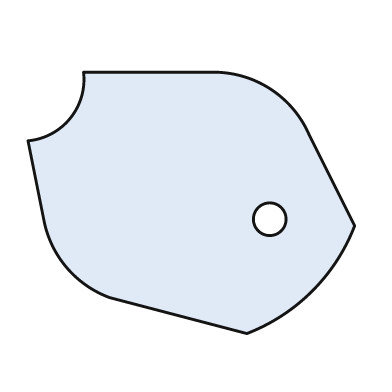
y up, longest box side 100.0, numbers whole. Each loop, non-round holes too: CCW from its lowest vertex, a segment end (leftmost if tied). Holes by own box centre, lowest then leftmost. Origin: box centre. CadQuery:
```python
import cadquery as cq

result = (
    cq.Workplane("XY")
    .moveTo(17.0, -40.0)
    .threePointArc((37.0, -27.0), (50.0, -7.0))
    .lineTo(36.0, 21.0)
    .threePointArc((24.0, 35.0), (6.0, 40.0))
    .lineTo(-33.0, 40.0)
    .threePointArc((-37.0, 26.0), (-50.0, 19.0))
    .lineTo(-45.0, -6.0)
    .threePointArc((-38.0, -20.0), (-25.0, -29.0))
    .close()
    .moveTo(24.0, -5.0)
    .circle(5.0)
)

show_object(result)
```